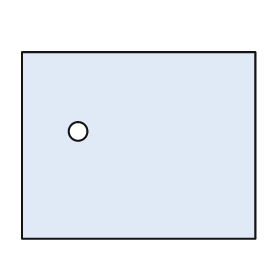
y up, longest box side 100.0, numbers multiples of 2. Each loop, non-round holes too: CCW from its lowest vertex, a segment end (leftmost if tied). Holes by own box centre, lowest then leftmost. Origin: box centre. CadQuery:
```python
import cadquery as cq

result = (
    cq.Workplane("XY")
    .moveTo(-50.0, -40.0)
    .lineTo(50.0, -40.0)
    .lineTo(50.0, 40.0)
    .lineTo(-50.0, 40.0)
    .close()
    .moveTo(-26.0, 6.0)
    .circle(4.0)
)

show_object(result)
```